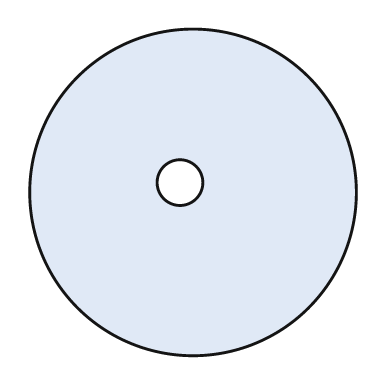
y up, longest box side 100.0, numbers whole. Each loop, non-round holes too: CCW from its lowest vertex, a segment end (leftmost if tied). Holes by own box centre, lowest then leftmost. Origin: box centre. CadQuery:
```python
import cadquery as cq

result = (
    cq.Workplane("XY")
    .moveTo(0.0, 0.0)
    .circle(50.0)
    .moveTo(-4.0, 3.0)
    .circle(7.0)
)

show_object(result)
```